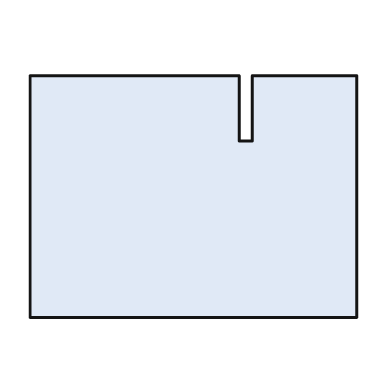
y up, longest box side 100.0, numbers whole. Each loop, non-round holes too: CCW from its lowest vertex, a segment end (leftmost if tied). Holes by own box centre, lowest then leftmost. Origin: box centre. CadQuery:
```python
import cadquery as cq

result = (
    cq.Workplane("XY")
    .moveTo(-50.0, -37.0)
    .lineTo(50.0, -37.0)
    .lineTo(50.0, 37.0)
    .lineTo(18.0, 37.0)
    .lineTo(18.0, 17.0)
    .lineTo(14.0, 17.0)
    .lineTo(14.0, 37.0)
    .lineTo(-50.0, 37.0)
    .close()
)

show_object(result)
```